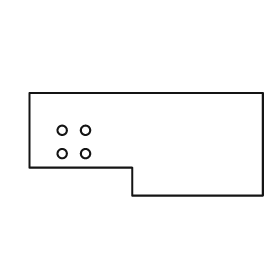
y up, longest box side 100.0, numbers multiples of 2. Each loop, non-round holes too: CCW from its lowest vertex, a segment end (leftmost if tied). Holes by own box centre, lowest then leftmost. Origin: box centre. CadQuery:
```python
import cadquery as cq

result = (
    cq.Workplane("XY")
    .moveTo(-6.0, -22.0)
    .lineTo(50.0, -22.0)
    .lineTo(50.0, 22.0)
    .lineTo(-50.0, 22.0)
    .lineTo(-50.0, -10.0)
    .lineTo(-6.0, -10.0)
    .close()
    .moveTo(-36.0, -4.0)
    .circle(2.0)
    .moveTo(-26.0, -4.0)
    .circle(2.0)
    .moveTo(-36.0, 6.0)
    .circle(2.0)
    .moveTo(-26.0, 6.0)
    .circle(2.0)
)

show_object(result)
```